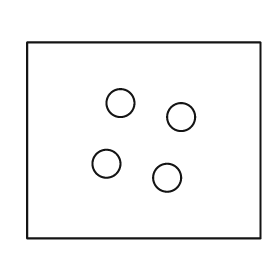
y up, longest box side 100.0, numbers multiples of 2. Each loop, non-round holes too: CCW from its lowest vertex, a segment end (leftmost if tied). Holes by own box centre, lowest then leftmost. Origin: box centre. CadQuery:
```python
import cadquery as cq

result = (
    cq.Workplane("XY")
    .moveTo(-50.0, -42.0)
    .lineTo(50.0, -42.0)
    .lineTo(50.0, 42.0)
    .lineTo(-50.0, 42.0)
    .close()
    .moveTo(10.0, -16.0)
    .circle(6.0)
    .moveTo(-16.0, -10.0)
    .circle(6.0)
    .moveTo(16.0, 10.0)
    .circle(6.0)
    .moveTo(-10.0, 16.0)
    .circle(6.0)
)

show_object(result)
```